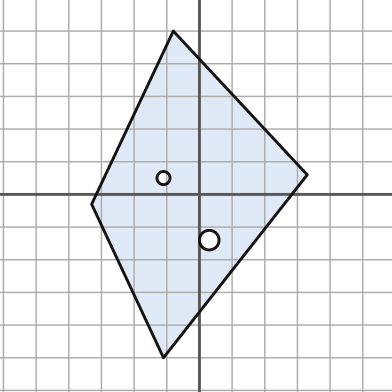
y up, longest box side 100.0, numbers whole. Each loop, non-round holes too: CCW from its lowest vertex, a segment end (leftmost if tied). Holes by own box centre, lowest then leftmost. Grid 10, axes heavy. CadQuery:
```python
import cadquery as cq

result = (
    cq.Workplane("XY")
    .moveTo(-11.0, -50.0)
    .lineTo(33.0, 6.0)
    .lineTo(-8.0, 50.0)
    .lineTo(-33.0, -3.0)
    .close()
    .moveTo(3.0, -14.0)
    .circle(3.0)
    .moveTo(-11.0, 5.0)
    .circle(2.0)
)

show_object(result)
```